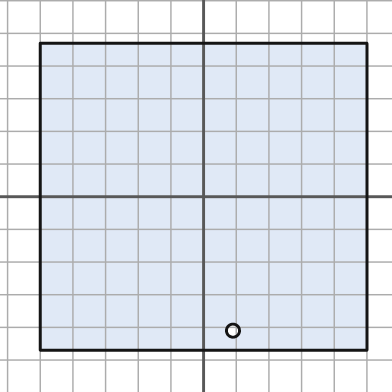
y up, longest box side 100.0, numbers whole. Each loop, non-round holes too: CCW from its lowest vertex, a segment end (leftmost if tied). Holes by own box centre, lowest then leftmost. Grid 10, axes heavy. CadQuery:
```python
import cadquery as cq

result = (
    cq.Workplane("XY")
    .moveTo(-50.0, -47.0)
    .lineTo(50.0, -47.0)
    .lineTo(50.0, 47.0)
    .lineTo(-50.0, 47.0)
    .close()
    .moveTo(9.0, -41.0)
    .circle(2.0)
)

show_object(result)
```